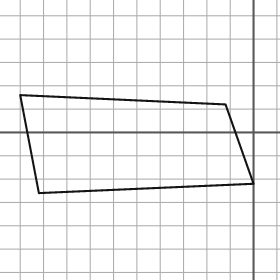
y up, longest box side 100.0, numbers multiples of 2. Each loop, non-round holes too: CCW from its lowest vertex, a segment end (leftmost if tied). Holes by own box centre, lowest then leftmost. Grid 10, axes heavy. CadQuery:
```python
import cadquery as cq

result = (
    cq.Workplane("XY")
    .moveTo(-92.0, -26.0)
    .lineTo(0.0, -22.0)
    .lineTo(-12.0, 12.0)
    .lineTo(-100.0, 16.0)
    .close()
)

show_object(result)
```